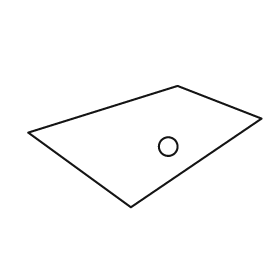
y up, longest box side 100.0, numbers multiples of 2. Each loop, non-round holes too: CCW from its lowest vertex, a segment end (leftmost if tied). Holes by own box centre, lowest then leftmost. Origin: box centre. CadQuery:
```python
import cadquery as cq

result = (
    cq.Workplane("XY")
    .moveTo(-6.0, -26.0)
    .lineTo(50.0, 12.0)
    .lineTo(14.0, 26.0)
    .lineTo(-50.0, 6.0)
    .close()
    .moveTo(10.0, 0.0)
    .circle(4.0)
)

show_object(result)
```